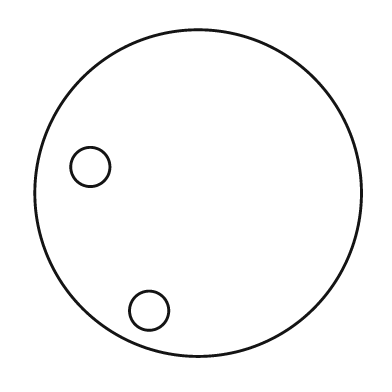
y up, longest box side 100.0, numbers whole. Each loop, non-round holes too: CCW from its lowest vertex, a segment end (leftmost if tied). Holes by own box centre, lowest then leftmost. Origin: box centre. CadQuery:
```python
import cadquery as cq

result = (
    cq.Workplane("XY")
    .moveTo(0.0, 0.0)
    .circle(50.0)
    .moveTo(-15.0, -36.0)
    .circle(6.0)
    .moveTo(-33.0, 8.0)
    .circle(6.0)
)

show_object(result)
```